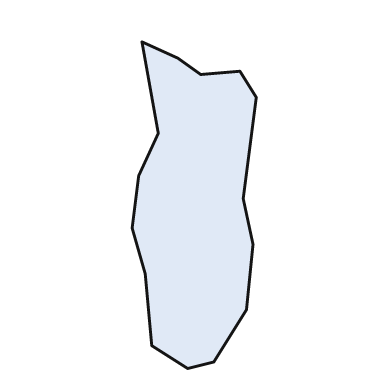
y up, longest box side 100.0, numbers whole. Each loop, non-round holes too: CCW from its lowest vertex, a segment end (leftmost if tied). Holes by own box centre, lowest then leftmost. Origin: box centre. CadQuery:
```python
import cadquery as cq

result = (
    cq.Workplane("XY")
    .moveTo(-2.0, -50.0)
    .lineTo(6.0, -48.0)
    .lineTo(16.0, -32.0)
    .lineTo(18.0, -12.0)
    .lineTo(15.0, 2.0)
    .lineTo(19.0, 33.0)
    .lineTo(14.0, 41.0)
    .lineTo(2.0, 40.0)
    .lineTo(-5.0, 45.0)
    .lineTo(-16.0, 50.0)
    .lineTo(-11.0, 22.0)
    .lineTo(-17.0, 9.0)
    .lineTo(-19.0, -7.0)
    .lineTo(-15.0, -21.0)
    .lineTo(-13.0, -43.0)
    .close()
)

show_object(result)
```